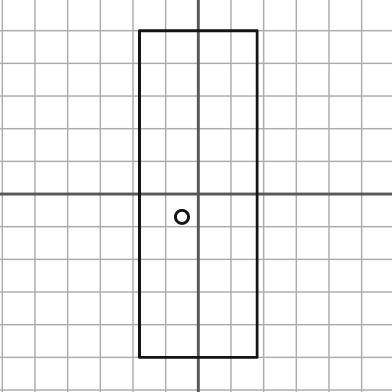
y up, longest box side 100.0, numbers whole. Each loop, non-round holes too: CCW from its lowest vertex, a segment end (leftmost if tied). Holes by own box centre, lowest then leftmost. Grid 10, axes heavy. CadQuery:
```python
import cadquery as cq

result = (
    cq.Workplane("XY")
    .moveTo(-18.0, -50.0)
    .lineTo(18.0, -50.0)
    .lineTo(18.0, 50.0)
    .lineTo(-18.0, 50.0)
    .close()
    .moveTo(-5.0, -7.0)
    .circle(2.0)
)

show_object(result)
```